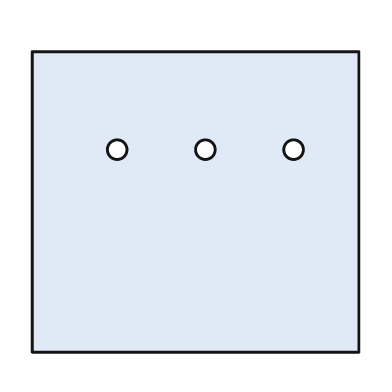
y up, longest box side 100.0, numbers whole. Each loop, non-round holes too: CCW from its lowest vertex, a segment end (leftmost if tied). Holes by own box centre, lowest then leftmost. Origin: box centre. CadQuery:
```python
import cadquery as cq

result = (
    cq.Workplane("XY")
    .moveTo(-50.0, -46.0)
    .lineTo(50.0, -46.0)
    .lineTo(50.0, 46.0)
    .lineTo(-50.0, 46.0)
    .close()
    .moveTo(-24.0, 16.0)
    .circle(3.0)
    .moveTo(3.0, 16.0)
    .circle(3.0)
    .moveTo(30.0, 16.0)
    .circle(3.0)
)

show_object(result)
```